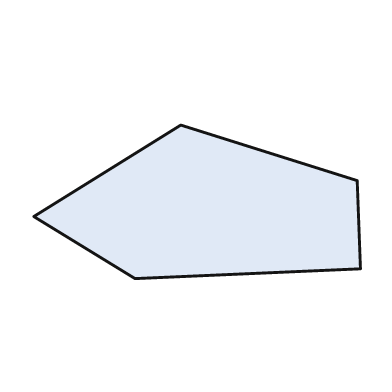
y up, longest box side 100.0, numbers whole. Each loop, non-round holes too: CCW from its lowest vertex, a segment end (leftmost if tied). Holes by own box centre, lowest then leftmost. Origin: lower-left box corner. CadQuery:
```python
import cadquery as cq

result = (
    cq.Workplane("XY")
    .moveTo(31.0, 0.0)
    .lineTo(100.0, 3.0)
    .lineTo(99.0, 30.0)
    .lineTo(45.0, 47.0)
    .lineTo(0.0, 19.0)
    .close()
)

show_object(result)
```